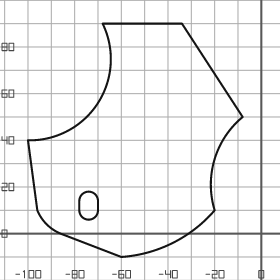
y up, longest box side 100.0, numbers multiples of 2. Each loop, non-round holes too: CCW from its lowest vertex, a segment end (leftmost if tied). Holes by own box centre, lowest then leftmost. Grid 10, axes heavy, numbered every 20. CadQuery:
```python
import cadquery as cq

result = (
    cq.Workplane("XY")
    .moveTo(-60.0, -10.0)
    .threePointArc((-38.0, -4.0), (-20.0, 10.0))
    .threePointArc((-20.0, 32.0), (-8.0, 50.0))
    .lineTo(-34.0, 90.0)
    .lineTo(-68.0, 90.0)
    .threePointArc((-70.0, 56.0), (-100.0, 40.0))
    .lineTo(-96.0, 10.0)
    .threePointArc((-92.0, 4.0), (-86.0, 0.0))
    .close()
    .moveTo(-78.0, 10.0)
    .threePointArc((-74.0, 6.0), (-70.0, 10.0))
    .lineTo(-70.0, 14.0)
    .threePointArc((-74.0, 18.0), (-78.0, 14.0))
    .close()
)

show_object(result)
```